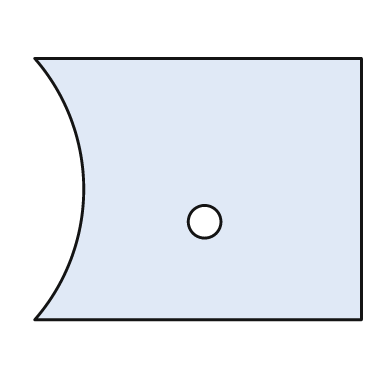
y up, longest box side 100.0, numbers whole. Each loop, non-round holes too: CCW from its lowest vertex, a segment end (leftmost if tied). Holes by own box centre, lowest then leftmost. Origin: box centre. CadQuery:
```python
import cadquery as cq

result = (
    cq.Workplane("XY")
    .moveTo(-50.0, -40.0)
    .lineTo(50.0, -40.0)
    .lineTo(50.0, 40.0)
    .lineTo(-50.0, 40.0)
    .threePointArc((-35.0, 0.0), (-50.0, -40.0))
    .close()
    .moveTo(2.0, -10.0)
    .circle(5.0)
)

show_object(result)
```